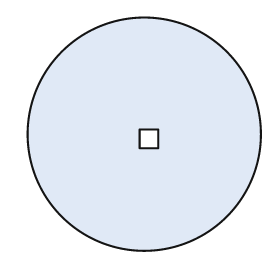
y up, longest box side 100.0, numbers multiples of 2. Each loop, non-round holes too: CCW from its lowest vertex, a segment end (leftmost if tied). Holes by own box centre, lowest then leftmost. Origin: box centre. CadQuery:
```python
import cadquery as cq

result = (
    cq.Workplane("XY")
    .moveTo(0.0, 0.0)
    .circle(50.0)
    .moveTo(-2.0, -6.0)
    .lineTo(6.0, -6.0)
    .lineTo(6.0, 2.0)
    .lineTo(-2.0, 2.0)
    .close()
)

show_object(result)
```